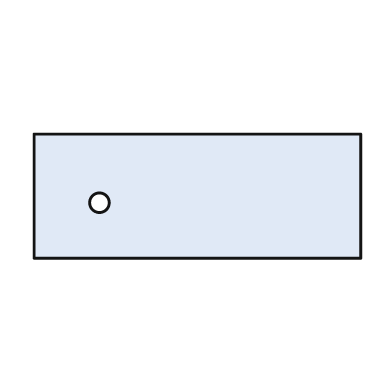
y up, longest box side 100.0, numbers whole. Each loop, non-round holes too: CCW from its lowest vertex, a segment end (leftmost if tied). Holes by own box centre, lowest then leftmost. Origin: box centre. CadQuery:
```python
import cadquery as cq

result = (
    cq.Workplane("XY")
    .moveTo(-50.0, -19.0)
    .lineTo(50.0, -19.0)
    .lineTo(50.0, 19.0)
    .lineTo(-50.0, 19.0)
    .close()
    .moveTo(-30.0, -2.0)
    .circle(3.0)
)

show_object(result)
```